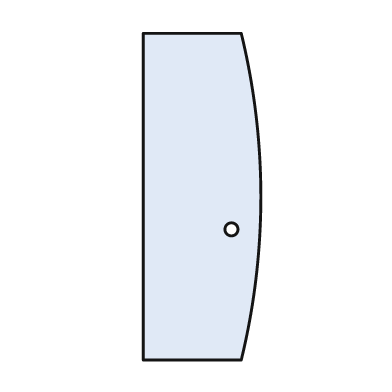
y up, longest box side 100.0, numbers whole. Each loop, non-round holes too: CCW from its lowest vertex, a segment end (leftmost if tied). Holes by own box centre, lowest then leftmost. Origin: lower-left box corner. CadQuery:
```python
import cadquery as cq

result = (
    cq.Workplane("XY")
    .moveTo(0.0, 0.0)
    .lineTo(30.0, 0.0)
    .threePointArc((36.0, 50.0), (30.0, 100.0))
    .lineTo(0.0, 100.0)
    .close()
    .moveTo(27.0, 40.0)
    .circle(2.0)
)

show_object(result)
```